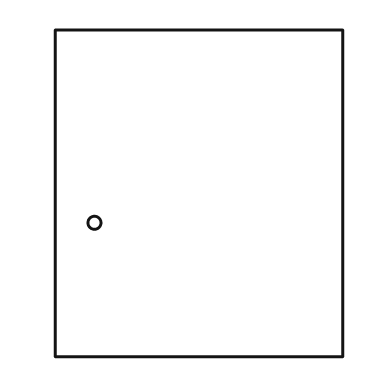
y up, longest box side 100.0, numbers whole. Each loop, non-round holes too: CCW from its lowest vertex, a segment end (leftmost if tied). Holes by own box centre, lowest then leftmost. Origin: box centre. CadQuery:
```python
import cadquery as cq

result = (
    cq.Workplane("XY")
    .moveTo(-44.0, -50.0)
    .lineTo(44.0, -50.0)
    .lineTo(44.0, 50.0)
    .lineTo(-44.0, 50.0)
    .close()
    .moveTo(-32.0, -9.0)
    .circle(2.0)
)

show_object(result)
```